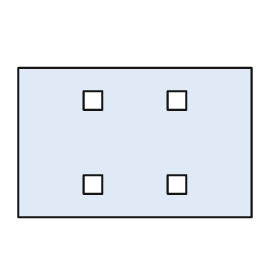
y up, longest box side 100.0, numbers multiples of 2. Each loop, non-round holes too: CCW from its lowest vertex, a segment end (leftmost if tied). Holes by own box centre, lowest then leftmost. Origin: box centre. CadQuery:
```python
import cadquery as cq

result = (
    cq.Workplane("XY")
    .moveTo(-50.0, -32.0)
    .lineTo(50.0, -32.0)
    .lineTo(50.0, 32.0)
    .lineTo(-50.0, 32.0)
    .close()
    .moveTo(-22.0, -22.0)
    .lineTo(-14.0, -22.0)
    .lineTo(-14.0, -14.0)
    .lineTo(-22.0, -14.0)
    .close()
    .moveTo(14.0, -22.0)
    .lineTo(22.0, -22.0)
    .lineTo(22.0, -14.0)
    .lineTo(14.0, -14.0)
    .close()
    .moveTo(-22.0, 14.0)
    .lineTo(-14.0, 14.0)
    .lineTo(-14.0, 22.0)
    .lineTo(-22.0, 22.0)
    .close()
    .moveTo(14.0, 14.0)
    .lineTo(22.0, 14.0)
    .lineTo(22.0, 22.0)
    .lineTo(14.0, 22.0)
    .close()
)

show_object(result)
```